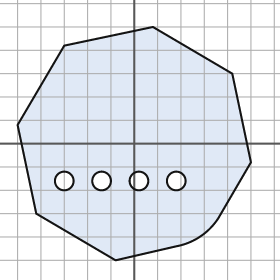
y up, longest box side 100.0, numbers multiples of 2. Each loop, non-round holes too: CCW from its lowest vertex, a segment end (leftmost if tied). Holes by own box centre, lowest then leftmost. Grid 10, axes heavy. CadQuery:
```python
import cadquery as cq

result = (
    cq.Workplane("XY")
    .moveTo(-8.0, -50.0)
    .lineTo(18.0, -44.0)
    .threePointArc((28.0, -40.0), (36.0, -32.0))
    .lineTo(50.0, -8.0)
    .lineTo(42.0, 30.0)
    .lineTo(8.0, 50.0)
    .lineTo(-30.0, 42.0)
    .lineTo(-50.0, 8.0)
    .lineTo(-42.0, -30.0)
    .close()
    .moveTo(-30.0, -16.0)
    .circle(4.0)
    .moveTo(-14.0, -16.0)
    .circle(4.0)
    .moveTo(2.0, -16.0)
    .circle(4.0)
    .moveTo(18.0, -16.0)
    .circle(4.0)
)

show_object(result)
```